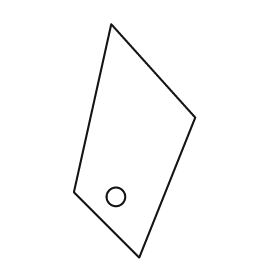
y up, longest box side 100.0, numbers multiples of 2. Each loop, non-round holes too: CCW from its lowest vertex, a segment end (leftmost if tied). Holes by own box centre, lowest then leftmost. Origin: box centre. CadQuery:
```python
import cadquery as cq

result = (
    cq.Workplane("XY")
    .moveTo(2.0, -50.0)
    .lineTo(26.0, 10.0)
    .lineTo(-10.0, 50.0)
    .lineTo(-26.0, -22.0)
    .close()
    .moveTo(-8.0, -24.0)
    .circle(4.0)
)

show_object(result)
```